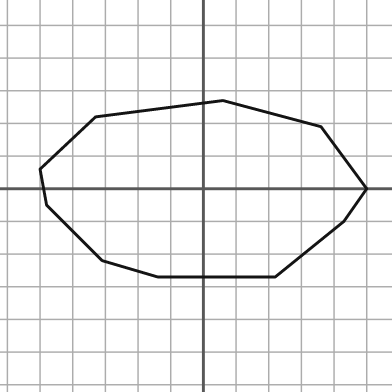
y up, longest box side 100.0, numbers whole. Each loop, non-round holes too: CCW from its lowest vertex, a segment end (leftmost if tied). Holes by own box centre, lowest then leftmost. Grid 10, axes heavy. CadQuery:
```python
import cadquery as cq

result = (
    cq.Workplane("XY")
    .moveTo(-14.0, -27.0)
    .lineTo(22.0, -27.0)
    .lineTo(43.0, -10.0)
    .lineTo(50.0, 0.0)
    .lineTo(36.0, 19.0)
    .lineTo(6.0, 27.0)
    .lineTo(-33.0, 22.0)
    .lineTo(-50.0, 6.0)
    .lineTo(-48.0, -5.0)
    .lineTo(-31.0, -22.0)
    .close()
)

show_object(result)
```